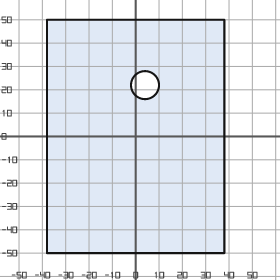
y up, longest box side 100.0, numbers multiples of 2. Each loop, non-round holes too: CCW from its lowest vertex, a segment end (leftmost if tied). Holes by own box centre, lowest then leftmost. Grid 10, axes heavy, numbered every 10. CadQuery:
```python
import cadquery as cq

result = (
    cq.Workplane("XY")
    .moveTo(-38.0, -50.0)
    .lineTo(38.0, -50.0)
    .lineTo(38.0, 50.0)
    .lineTo(-38.0, 50.0)
    .close()
    .moveTo(4.0, 22.0)
    .circle(6.0)
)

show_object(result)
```